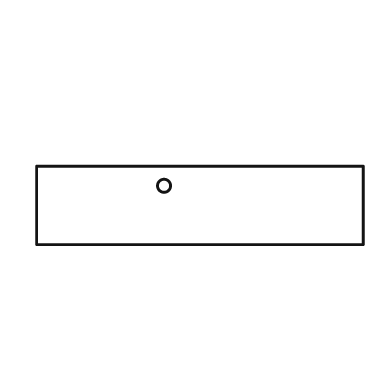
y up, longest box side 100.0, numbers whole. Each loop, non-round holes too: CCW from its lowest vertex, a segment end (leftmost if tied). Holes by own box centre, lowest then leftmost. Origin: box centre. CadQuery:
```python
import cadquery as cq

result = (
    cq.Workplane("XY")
    .moveTo(-50.0, -12.0)
    .lineTo(50.0, -12.0)
    .lineTo(50.0, 12.0)
    .lineTo(-50.0, 12.0)
    .close()
    .moveTo(-11.0, 6.0)
    .circle(2.0)
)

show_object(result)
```